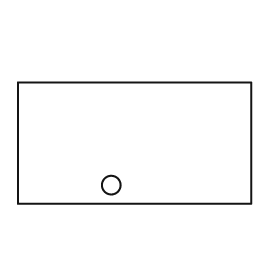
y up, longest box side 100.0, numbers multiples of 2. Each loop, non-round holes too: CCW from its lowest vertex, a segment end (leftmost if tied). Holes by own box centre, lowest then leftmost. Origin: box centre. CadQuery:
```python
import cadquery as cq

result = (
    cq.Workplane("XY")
    .moveTo(-50.0, -26.0)
    .lineTo(50.0, -26.0)
    .lineTo(50.0, 26.0)
    .lineTo(-50.0, 26.0)
    .close()
    .moveTo(-10.0, -18.0)
    .circle(4.0)
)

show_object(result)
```